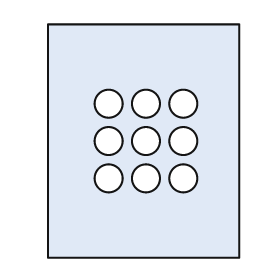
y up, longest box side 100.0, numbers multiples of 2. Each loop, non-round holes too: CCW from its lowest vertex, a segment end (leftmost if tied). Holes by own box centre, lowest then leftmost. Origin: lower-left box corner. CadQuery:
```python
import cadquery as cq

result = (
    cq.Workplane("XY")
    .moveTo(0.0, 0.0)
    .lineTo(82.0, 0.0)
    .lineTo(82.0, 100.0)
    .lineTo(0.0, 100.0)
    .close()
    .moveTo(26.0, 34.0)
    .circle(6.0)
    .moveTo(42.0, 34.0)
    .circle(6.0)
    .moveTo(58.0, 34.0)
    .circle(6.0)
    .moveTo(26.0, 50.0)
    .circle(6.0)
    .moveTo(42.0, 50.0)
    .circle(6.0)
    .moveTo(58.0, 50.0)
    .circle(6.0)
    .moveTo(26.0, 66.0)
    .circle(6.0)
    .moveTo(42.0, 66.0)
    .circle(6.0)
    .moveTo(58.0, 66.0)
    .circle(6.0)
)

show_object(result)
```